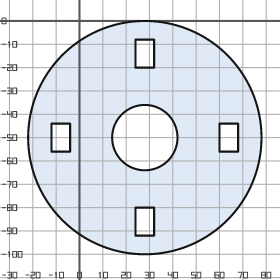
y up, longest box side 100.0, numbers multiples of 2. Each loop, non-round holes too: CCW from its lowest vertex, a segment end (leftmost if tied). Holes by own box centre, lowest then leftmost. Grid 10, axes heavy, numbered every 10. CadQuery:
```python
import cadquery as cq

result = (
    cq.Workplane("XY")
    .moveTo(28.0, -50.0)
    .circle(50.0)
    .moveTo(24.0, -92.0)
    .lineTo(32.0, -92.0)
    .lineTo(32.0, -80.0)
    .lineTo(24.0, -80.0)
    .close()
    .moveTo(-12.0, -56.0)
    .lineTo(-4.0, -56.0)
    .lineTo(-4.0, -44.0)
    .lineTo(-12.0, -44.0)
    .close()
    .moveTo(28.0, -50.0)
    .circle(14.0)
    .moveTo(60.0, -56.0)
    .lineTo(68.0, -56.0)
    .lineTo(68.0, -44.0)
    .lineTo(60.0, -44.0)
    .close()
    .moveTo(24.0, -20.0)
    .lineTo(32.0, -20.0)
    .lineTo(32.0, -8.0)
    .lineTo(24.0, -8.0)
    .close()
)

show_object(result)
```